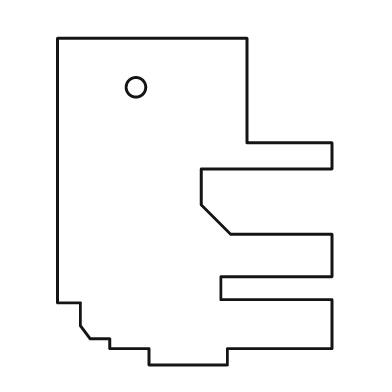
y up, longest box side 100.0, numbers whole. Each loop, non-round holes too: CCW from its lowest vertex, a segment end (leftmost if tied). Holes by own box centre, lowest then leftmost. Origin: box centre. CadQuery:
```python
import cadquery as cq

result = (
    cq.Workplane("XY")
    .moveTo(-14.0, -50.0)
    .lineTo(10.0, -50.0)
    .lineTo(10.0, -45.0)
    .lineTo(42.0, -45.0)
    .lineTo(42.0, -30.0)
    .lineTo(8.0, -30.0)
    .lineTo(8.0, -23.0)
    .lineTo(42.0, -23.0)
    .lineTo(42.0, -10.0)
    .lineTo(11.0, -10.0)
    .lineTo(2.0, -1.0)
    .lineTo(2.0, 10.0)
    .lineTo(42.0, 10.0)
    .lineTo(42.0, 18.0)
    .lineTo(16.0, 18.0)
    .lineTo(16.0, 50.0)
    .lineTo(-42.0, 50.0)
    .lineTo(-42.0, -31.0)
    .lineTo(-35.0, -31.0)
    .lineTo(-35.0, -38.0)
    .lineTo(-32.0, -42.0)
    .lineTo(-26.0, -42.0)
    .lineTo(-26.0, -45.0)
    .lineTo(-14.0, -45.0)
    .close()
    .moveTo(-18.0, 35.0)
    .circle(3.0)
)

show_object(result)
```